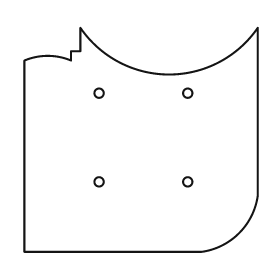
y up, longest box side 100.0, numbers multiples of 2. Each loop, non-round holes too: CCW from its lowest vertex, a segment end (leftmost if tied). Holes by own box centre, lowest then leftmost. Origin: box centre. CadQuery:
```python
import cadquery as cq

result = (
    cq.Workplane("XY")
    .moveTo(-50.0, -48.0)
    .lineTo(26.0, -48.0)
    .threePointArc((42.0, -40.0), (50.0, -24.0))
    .lineTo(50.0, 48.0)
    .threePointArc((12.0, 28.0), (-26.0, 48.0))
    .lineTo(-26.0, 38.0)
    .lineTo(-30.0, 38.0)
    .lineTo(-30.0, 34.0)
    .threePointArc((-40.0, 36.0), (-50.0, 34.0))
    .close()
    .moveTo(-18.0, -18.0)
    .circle(2.0)
    .moveTo(20.0, -18.0)
    .circle(2.0)
    .moveTo(-18.0, 20.0)
    .circle(2.0)
    .moveTo(20.0, 20.0)
    .circle(2.0)
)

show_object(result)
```